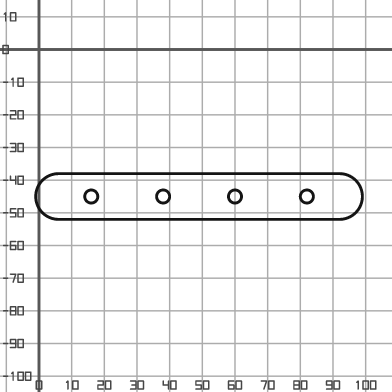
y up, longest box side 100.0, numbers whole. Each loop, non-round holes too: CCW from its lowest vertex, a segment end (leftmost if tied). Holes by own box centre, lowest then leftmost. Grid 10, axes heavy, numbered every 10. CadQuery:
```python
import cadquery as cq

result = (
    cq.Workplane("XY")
    .moveTo(6.0, -52.0)
    .lineTo(92.0, -52.0)
    .threePointArc((99.0, -45.0), (92.0, -38.0))
    .lineTo(6.0, -38.0)
    .threePointArc((-1.0, -45.0), (6.0, -52.0))
    .close()
    .moveTo(16.0, -45.0)
    .circle(2.0)
    .moveTo(38.0, -45.0)
    .circle(2.0)
    .moveTo(60.0, -45.0)
    .circle(2.0)
    .moveTo(82.0, -45.0)
    .circle(2.0)
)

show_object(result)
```